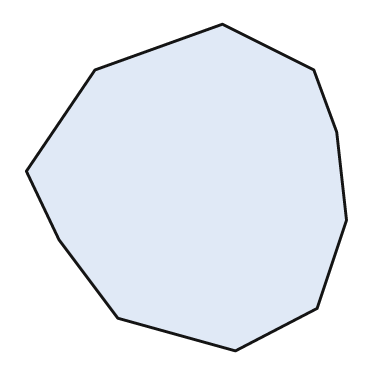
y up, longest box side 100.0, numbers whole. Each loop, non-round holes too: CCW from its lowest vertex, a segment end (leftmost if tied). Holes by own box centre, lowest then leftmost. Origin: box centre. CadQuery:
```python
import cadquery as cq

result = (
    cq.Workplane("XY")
    .moveTo(15.0, -50.0)
    .lineTo(40.0, -37.0)
    .lineTo(49.0, -10.0)
    .lineTo(46.0, 17.0)
    .lineTo(39.0, 36.0)
    .lineTo(11.0, 50.0)
    .lineTo(-28.0, 36.0)
    .lineTo(-49.0, 5.0)
    .lineTo(-39.0, -16.0)
    .lineTo(-21.0, -40.0)
    .close()
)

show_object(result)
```